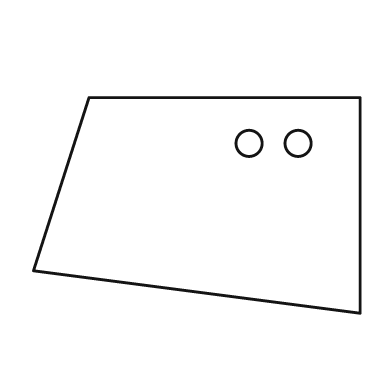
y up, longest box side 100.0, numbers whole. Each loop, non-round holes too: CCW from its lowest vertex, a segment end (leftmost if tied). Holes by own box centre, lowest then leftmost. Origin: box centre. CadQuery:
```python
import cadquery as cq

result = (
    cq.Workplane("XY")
    .moveTo(50.0, -33.0)
    .lineTo(50.0, 33.0)
    .lineTo(-33.0, 33.0)
    .lineTo(-50.0, -20.0)
    .close()
    .moveTo(16.0, 19.0)
    .circle(4.0)
    .moveTo(31.0, 19.0)
    .circle(4.0)
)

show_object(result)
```